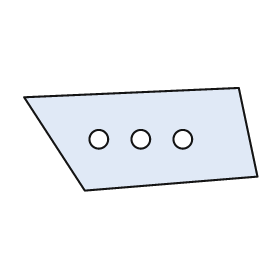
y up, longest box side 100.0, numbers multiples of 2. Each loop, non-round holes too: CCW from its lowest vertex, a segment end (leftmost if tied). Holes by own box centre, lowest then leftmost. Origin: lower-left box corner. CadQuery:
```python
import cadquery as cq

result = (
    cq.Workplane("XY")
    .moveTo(26.0, 0.0)
    .lineTo(100.0, 6.0)
    .lineTo(92.0, 44.0)
    .lineTo(0.0, 40.0)
    .close()
    .moveTo(32.0, 22.0)
    .circle(4.0)
    .moveTo(50.0, 22.0)
    .circle(4.0)
    .moveTo(68.0, 22.0)
    .circle(4.0)
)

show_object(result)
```